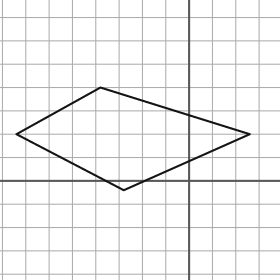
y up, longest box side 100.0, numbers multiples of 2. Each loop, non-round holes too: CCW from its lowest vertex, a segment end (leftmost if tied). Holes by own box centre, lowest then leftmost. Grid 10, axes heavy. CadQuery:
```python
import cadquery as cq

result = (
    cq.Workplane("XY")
    .moveTo(-28.0, -4.0)
    .lineTo(26.0, 20.0)
    .lineTo(-38.0, 40.0)
    .lineTo(-74.0, 20.0)
    .close()
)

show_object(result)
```